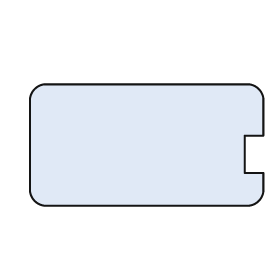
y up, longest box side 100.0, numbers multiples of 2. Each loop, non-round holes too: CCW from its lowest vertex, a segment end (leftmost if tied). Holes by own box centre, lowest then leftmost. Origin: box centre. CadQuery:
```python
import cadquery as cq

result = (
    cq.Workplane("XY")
    .moveTo(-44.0, -26.0)
    .lineTo(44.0, -26.0)
    .threePointArc((48.0, -24.0), (50.0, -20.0))
    .lineTo(50.0, -12.0)
    .lineTo(42.0, -12.0)
    .lineTo(42.0, 4.0)
    .lineTo(50.0, 4.0)
    .lineTo(50.0, 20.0)
    .threePointArc((48.0, 24.0), (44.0, 26.0))
    .lineTo(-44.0, 26.0)
    .threePointArc((-48.0, 24.0), (-50.0, 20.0))
    .lineTo(-50.0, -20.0)
    .threePointArc((-48.0, -24.0), (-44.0, -26.0))
    .close()
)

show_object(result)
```